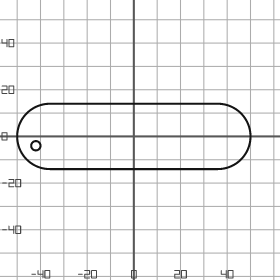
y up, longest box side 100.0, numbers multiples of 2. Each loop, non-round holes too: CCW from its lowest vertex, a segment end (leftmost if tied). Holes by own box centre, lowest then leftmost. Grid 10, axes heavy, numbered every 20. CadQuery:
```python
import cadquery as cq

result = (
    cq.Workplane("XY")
    .moveTo(-36.0, -14.0)
    .lineTo(36.0, -14.0)
    .threePointArc((50.0, 0.0), (36.0, 14.0))
    .lineTo(-36.0, 14.0)
    .threePointArc((-50.0, 0.0), (-36.0, -14.0))
    .close()
    .moveTo(-42.0, -4.0)
    .circle(2.0)
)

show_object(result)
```